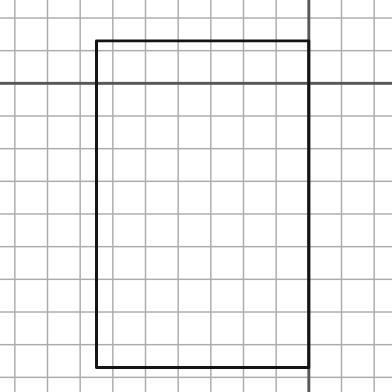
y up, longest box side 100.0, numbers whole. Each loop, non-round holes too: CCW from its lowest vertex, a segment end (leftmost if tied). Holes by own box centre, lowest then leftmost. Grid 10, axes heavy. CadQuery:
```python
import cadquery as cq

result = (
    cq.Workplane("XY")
    .moveTo(-65.0, -87.0)
    .lineTo(0.0, -87.0)
    .lineTo(0.0, 13.0)
    .lineTo(-65.0, 13.0)
    .close()
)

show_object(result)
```